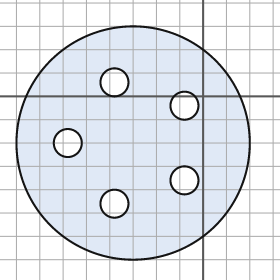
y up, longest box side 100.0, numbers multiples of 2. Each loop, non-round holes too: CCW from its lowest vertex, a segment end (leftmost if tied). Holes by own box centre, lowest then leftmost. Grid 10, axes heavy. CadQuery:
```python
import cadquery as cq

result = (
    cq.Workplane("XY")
    .moveTo(-30.0, -20.0)
    .circle(50.0)
    .moveTo(-38.0, -46.0)
    .circle(6.0)
    .moveTo(-8.0, -36.0)
    .circle(6.0)
    .moveTo(-58.0, -20.0)
    .circle(6.0)
    .moveTo(-8.0, -4.0)
    .circle(6.0)
    .moveTo(-38.0, 6.0)
    .circle(6.0)
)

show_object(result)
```